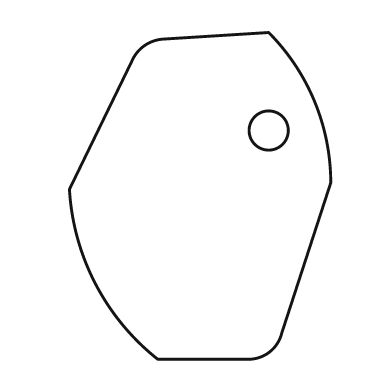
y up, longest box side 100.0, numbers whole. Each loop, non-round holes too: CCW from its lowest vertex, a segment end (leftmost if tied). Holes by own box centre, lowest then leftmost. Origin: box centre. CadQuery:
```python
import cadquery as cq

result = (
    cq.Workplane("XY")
    .moveTo(-13.0, -50.0)
    .lineTo(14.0, -50.0)
    .threePointArc((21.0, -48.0), (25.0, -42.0))
    .lineTo(40.0, 4.0)
    .threePointArc((35.0, 29.0), (21.0, 50.0))
    .lineTo(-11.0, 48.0)
    .threePointArc((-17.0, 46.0), (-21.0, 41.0))
    .lineTo(-40.0, 2.0)
    .threePointArc((-32.0, -27.0), (-13.0, -50.0))
    .close()
    .moveTo(21.0, 20.0)
    .circle(6.0)
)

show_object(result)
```